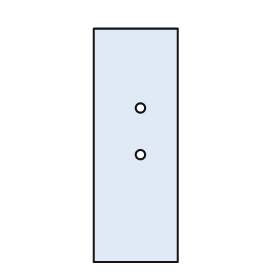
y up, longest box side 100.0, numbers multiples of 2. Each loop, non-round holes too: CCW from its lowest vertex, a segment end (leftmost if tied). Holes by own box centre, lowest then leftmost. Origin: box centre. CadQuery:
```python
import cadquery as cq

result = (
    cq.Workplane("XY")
    .moveTo(-18.0, -50.0)
    .lineTo(18.0, -50.0)
    .lineTo(18.0, 50.0)
    .lineTo(-18.0, 50.0)
    .close()
    .moveTo(2.0, -4.0)
    .circle(2.0)
    .moveTo(2.0, 16.0)
    .circle(2.0)
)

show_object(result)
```